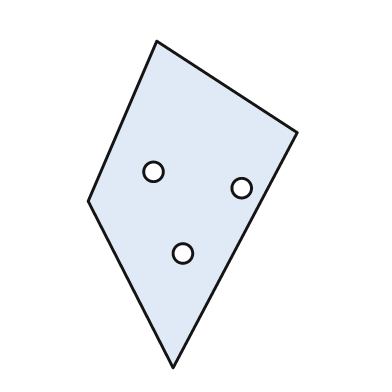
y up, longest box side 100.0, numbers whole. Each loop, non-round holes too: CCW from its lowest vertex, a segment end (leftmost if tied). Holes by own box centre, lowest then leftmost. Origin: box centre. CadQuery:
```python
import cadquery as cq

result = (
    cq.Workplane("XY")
    .moveTo(-6.0, -50.0)
    .lineTo(32.0, 22.0)
    .lineTo(-11.0, 50.0)
    .lineTo(-32.0, 1.0)
    .close()
    .moveTo(-3.0, -15.0)
    .circle(3.0)
    .moveTo(15.0, 5.0)
    .circle(3.0)
    .moveTo(-12.0, 10.0)
    .circle(3.0)
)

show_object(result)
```